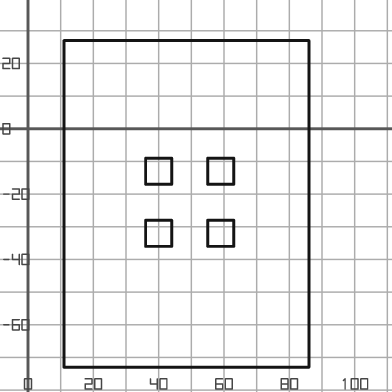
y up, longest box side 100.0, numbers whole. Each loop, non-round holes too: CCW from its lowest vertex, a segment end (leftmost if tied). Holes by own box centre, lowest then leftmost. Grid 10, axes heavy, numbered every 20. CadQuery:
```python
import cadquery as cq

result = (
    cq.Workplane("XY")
    .moveTo(11.0, -73.0)
    .lineTo(86.0, -73.0)
    .lineTo(86.0, 27.0)
    .lineTo(11.0, 27.0)
    .close()
    .moveTo(36.0, -36.0)
    .lineTo(44.0, -36.0)
    .lineTo(44.0, -28.0)
    .lineTo(36.0, -28.0)
    .close()
    .moveTo(55.0, -36.0)
    .lineTo(63.0, -36.0)
    .lineTo(63.0, -28.0)
    .lineTo(55.0, -28.0)
    .close()
    .moveTo(36.0, -17.0)
    .lineTo(44.0, -17.0)
    .lineTo(44.0, -9.0)
    .lineTo(36.0, -9.0)
    .close()
    .moveTo(55.0, -17.0)
    .lineTo(63.0, -17.0)
    .lineTo(63.0, -9.0)
    .lineTo(55.0, -9.0)
    .close()
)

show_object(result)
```